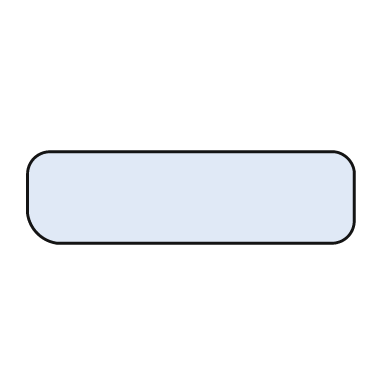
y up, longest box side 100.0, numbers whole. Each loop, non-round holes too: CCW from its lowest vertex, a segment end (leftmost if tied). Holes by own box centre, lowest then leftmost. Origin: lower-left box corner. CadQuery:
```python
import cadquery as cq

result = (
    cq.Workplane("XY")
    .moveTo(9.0, 0.0)
    .lineTo(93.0, 0.0)
    .threePointArc((98.0, 2.0), (100.0, 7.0))
    .lineTo(100.0, 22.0)
    .threePointArc((98.0, 26.0), (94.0, 28.0))
    .lineTo(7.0, 28.0)
    .threePointArc((2.0, 26.0), (0.0, 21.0))
    .lineTo(0.0, 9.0)
    .threePointArc((3.0, 3.0), (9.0, 0.0))
    .close()
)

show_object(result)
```